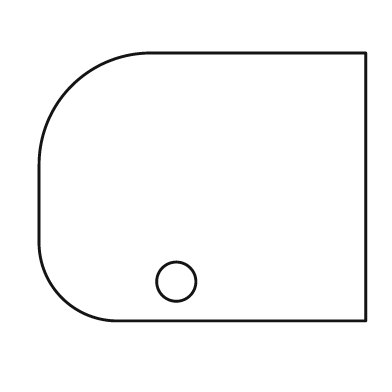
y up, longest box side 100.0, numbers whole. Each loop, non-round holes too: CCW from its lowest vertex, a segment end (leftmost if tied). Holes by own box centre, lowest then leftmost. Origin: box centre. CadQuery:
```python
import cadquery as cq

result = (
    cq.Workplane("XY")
    .moveTo(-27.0, -41.0)
    .lineTo(50.0, -41.0)
    .lineTo(50.0, 41.0)
    .lineTo(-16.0, 41.0)
    .threePointArc((-40.0, 31.0), (-50.0, 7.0))
    .lineTo(-50.0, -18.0)
    .threePointArc((-43.0, -34.0), (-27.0, -41.0))
    .close()
    .moveTo(-8.0, -29.0)
    .circle(6.0)
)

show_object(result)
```